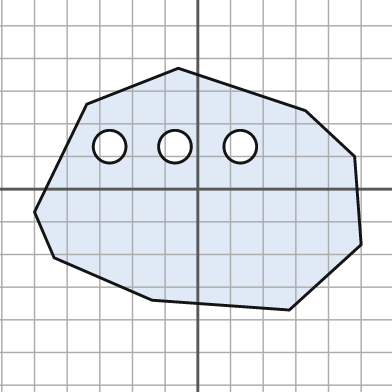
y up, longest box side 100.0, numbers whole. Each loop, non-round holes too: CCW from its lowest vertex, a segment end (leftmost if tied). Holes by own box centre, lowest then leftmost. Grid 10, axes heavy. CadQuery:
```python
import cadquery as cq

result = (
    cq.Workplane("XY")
    .moveTo(28.0, -37.0)
    .lineTo(50.0, -17.0)
    .lineTo(48.0, 10.0)
    .lineTo(33.0, 24.0)
    .lineTo(-6.0, 37.0)
    .lineTo(-34.0, 26.0)
    .lineTo(-50.0, -7.0)
    .lineTo(-44.0, -21.0)
    .lineTo(-14.0, -34.0)
    .close()
    .moveTo(-27.0, 13.0)
    .circle(5.0)
    .moveTo(-7.0, 13.0)
    .circle(5.0)
    .moveTo(13.0, 13.0)
    .circle(5.0)
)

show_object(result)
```